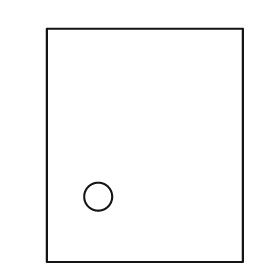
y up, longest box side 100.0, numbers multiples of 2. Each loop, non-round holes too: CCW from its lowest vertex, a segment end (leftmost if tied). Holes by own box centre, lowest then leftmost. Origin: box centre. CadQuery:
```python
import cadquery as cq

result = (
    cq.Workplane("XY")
    .moveTo(-42.0, -50.0)
    .lineTo(42.0, -50.0)
    .lineTo(42.0, 50.0)
    .lineTo(-42.0, 50.0)
    .close()
    .moveTo(-20.0, -22.0)
    .circle(6.0)
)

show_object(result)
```